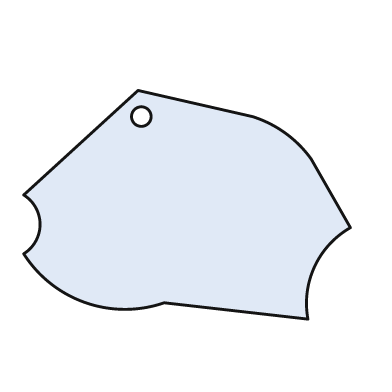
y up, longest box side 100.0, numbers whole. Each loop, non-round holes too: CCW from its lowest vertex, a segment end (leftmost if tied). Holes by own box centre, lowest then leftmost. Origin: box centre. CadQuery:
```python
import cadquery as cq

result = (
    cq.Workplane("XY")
    .moveTo(37.0, -35.0)
    .threePointArc((39.0, -19.0), (50.0, -7.0))
    .lineTo(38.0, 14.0)
    .threePointArc((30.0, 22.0), (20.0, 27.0))
    .lineTo(-15.0, 35.0)
    .lineTo(-50.0, 3.0)
    .threePointArc((-45.0, -6.0), (-50.0, -15.0))
    .threePointArc((-31.0, -30.0), (-7.0, -30.0))
    .close()
    .moveTo(-14.0, 27.0)
    .circle(3.0)
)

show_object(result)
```